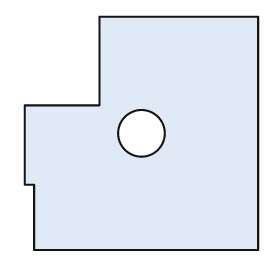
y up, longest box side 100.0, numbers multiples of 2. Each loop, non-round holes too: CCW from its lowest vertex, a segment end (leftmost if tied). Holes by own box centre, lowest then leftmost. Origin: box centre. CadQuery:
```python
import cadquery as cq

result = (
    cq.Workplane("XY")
    .moveTo(-46.0, -50.0)
    .lineTo(50.0, -50.0)
    .lineTo(50.0, 50.0)
    .lineTo(-18.0, 50.0)
    .lineTo(-18.0, 12.0)
    .lineTo(-50.0, 12.0)
    .lineTo(-50.0, -22.0)
    .lineTo(-46.0, -22.0)
    .close()
    .moveTo(0.0, 0.0)
    .circle(10.0)
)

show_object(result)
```